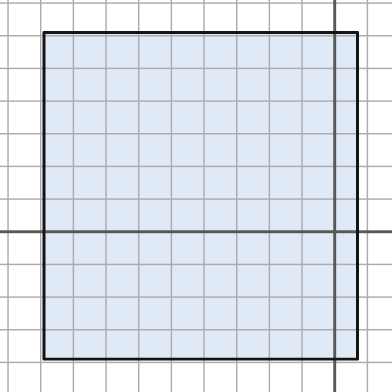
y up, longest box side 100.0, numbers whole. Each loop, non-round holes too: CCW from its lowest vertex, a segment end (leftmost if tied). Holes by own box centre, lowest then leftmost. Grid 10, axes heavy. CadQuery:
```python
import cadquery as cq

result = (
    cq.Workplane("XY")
    .moveTo(-89.0, -39.0)
    .lineTo(7.0, -39.0)
    .lineTo(7.0, 61.0)
    .lineTo(-89.0, 61.0)
    .close()
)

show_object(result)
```